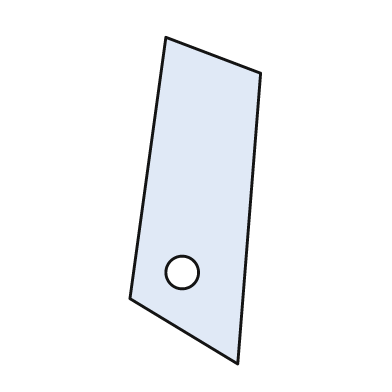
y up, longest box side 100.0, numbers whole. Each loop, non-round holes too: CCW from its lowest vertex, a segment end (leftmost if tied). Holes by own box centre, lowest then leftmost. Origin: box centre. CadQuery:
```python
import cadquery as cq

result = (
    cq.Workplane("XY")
    .moveTo(13.0, -50.0)
    .lineTo(20.0, 39.0)
    .lineTo(-9.0, 50.0)
    .lineTo(-20.0, -30.0)
    .close()
    .moveTo(-4.0, -22.0)
    .circle(5.0)
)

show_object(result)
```